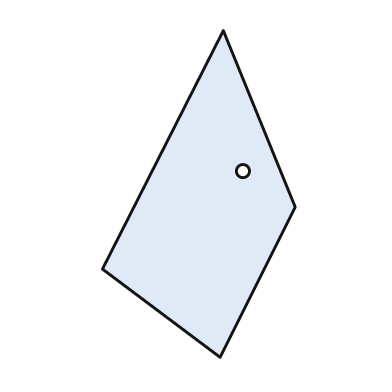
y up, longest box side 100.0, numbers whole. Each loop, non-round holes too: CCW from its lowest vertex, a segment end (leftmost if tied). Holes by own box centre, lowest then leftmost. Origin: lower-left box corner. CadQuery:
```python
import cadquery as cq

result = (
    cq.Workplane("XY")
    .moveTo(36.0, 0.0)
    .lineTo(59.0, 46.0)
    .lineTo(37.0, 100.0)
    .lineTo(0.0, 27.0)
    .close()
    .moveTo(43.0, 57.0)
    .circle(2.0)
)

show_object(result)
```